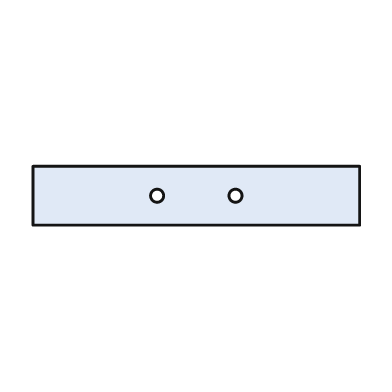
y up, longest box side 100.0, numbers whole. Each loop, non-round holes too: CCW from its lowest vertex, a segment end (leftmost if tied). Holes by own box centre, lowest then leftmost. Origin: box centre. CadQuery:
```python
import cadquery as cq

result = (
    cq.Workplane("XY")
    .moveTo(-50.0, -9.0)
    .lineTo(50.0, -9.0)
    .lineTo(50.0, 9.0)
    .lineTo(-50.0, 9.0)
    .close()
    .moveTo(-12.0, 0.0)
    .circle(2.0)
    .moveTo(12.0, 0.0)
    .circle(2.0)
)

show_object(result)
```